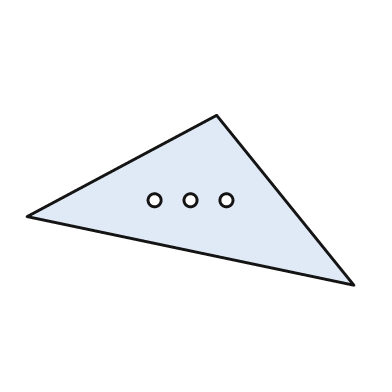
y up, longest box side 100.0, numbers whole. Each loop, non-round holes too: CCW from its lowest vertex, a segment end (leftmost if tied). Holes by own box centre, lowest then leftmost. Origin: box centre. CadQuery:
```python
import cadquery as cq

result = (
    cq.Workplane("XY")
    .moveTo(50.0, -26.0)
    .lineTo(8.0, 26.0)
    .lineTo(-50.0, -5.0)
    .close()
    .moveTo(-11.0, 0.0)
    .circle(2.0)
    .moveTo(0.0, 0.0)
    .circle(2.0)
    .moveTo(11.0, 0.0)
    .circle(2.0)
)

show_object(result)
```